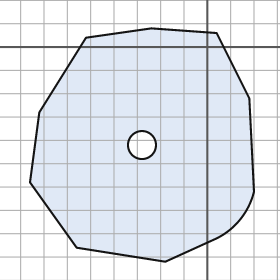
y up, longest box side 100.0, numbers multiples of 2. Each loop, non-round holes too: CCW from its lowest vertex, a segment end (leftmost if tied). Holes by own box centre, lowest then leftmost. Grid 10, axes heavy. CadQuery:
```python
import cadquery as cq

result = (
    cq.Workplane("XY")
    .moveTo(-18.0, -92.0)
    .lineTo(4.0, -82.0)
    .threePointArc((14.0, -74.0), (20.0, -62.0))
    .lineTo(18.0, -22.0)
    .lineTo(4.0, 6.0)
    .lineTo(-24.0, 8.0)
    .lineTo(-52.0, 4.0)
    .lineTo(-72.0, -28.0)
    .lineTo(-76.0, -58.0)
    .lineTo(-56.0, -86.0)
    .close()
    .moveTo(-28.0, -42.0)
    .circle(6.0)
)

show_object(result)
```